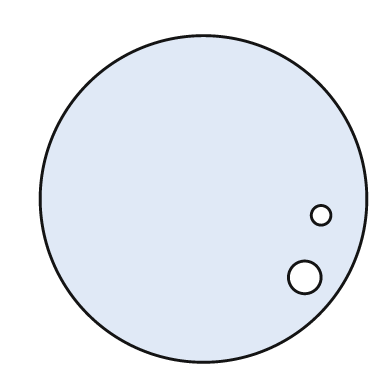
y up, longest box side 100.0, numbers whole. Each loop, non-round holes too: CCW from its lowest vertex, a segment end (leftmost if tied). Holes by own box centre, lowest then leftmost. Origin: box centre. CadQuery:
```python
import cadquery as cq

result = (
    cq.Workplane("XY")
    .moveTo(0.0, 0.0)
    .circle(50.0)
    .moveTo(31.0, -24.0)
    .circle(5.0)
    .moveTo(36.0, -5.0)
    .circle(3.0)
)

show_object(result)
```